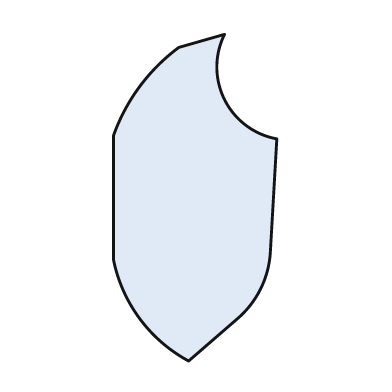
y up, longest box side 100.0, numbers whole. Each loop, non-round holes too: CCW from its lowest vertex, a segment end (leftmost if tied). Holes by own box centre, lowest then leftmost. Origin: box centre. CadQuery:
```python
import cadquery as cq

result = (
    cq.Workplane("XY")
    .moveTo(-2.0, -50.0)
    .lineTo(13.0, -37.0)
    .threePointArc((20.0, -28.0), (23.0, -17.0))
    .lineTo(25.0, 18.0)
    .threePointArc((9.0, 30.0), (9.0, 50.0))
    .lineTo(-5.0, 46.0)
    .threePointArc((-17.0, 34.0), (-25.0, 19.0))
    .lineTo(-25.0, -19.0)
    .threePointArc((-17.0, -37.0), (-2.0, -50.0))
    .close()
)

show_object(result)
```